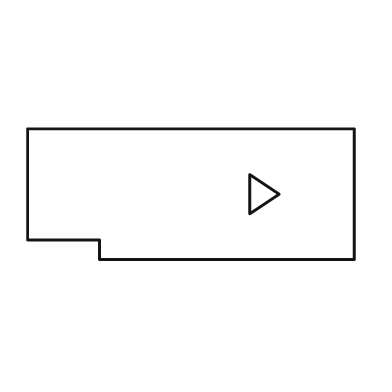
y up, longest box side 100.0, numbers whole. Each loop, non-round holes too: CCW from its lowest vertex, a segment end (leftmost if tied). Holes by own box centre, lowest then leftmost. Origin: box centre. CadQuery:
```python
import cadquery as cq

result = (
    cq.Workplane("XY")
    .moveTo(-28.0, -20.0)
    .lineTo(50.0, -20.0)
    .lineTo(50.0, 20.0)
    .lineTo(-50.0, 20.0)
    .lineTo(-50.0, -14.0)
    .lineTo(-28.0, -14.0)
    .close()
    .moveTo(18.0, -6.0)
    .lineTo(27.0, 0.0)
    .lineTo(18.0, 6.0)
    .close()
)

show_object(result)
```